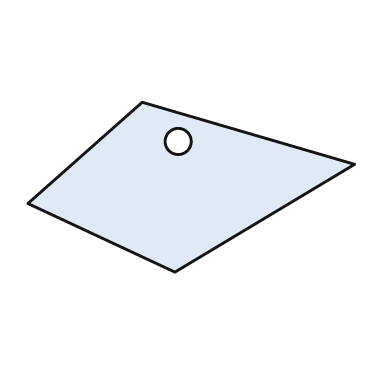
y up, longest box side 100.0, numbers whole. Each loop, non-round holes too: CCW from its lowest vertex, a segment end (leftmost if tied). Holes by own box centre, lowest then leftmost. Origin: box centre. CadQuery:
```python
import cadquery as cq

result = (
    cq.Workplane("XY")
    .moveTo(-5.0, -26.0)
    .lineTo(50.0, 7.0)
    .lineTo(-15.0, 26.0)
    .lineTo(-50.0, -5.0)
    .close()
    .moveTo(-4.0, 14.0)
    .circle(4.0)
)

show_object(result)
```